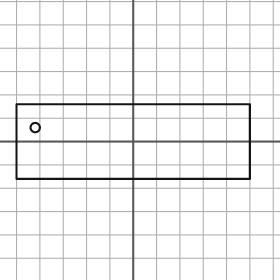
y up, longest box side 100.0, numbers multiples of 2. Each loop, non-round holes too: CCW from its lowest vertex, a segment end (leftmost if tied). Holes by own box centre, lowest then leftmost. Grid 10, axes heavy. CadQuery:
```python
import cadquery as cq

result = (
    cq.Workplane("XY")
    .moveTo(-50.0, -16.0)
    .lineTo(50.0, -16.0)
    .lineTo(50.0, 16.0)
    .lineTo(-50.0, 16.0)
    .close()
    .moveTo(-42.0, 6.0)
    .circle(2.0)
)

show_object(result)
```